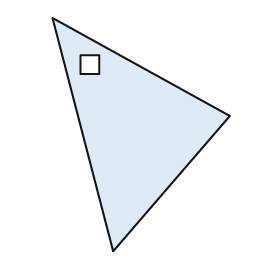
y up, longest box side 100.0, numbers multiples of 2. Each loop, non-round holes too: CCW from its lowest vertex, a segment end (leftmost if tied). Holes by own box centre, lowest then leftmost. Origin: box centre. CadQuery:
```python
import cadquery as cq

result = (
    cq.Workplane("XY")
    .moveTo(-12.0, -50.0)
    .lineTo(38.0, 8.0)
    .lineTo(-38.0, 50.0)
    .close()
    .moveTo(-26.0, 26.0)
    .lineTo(-18.0, 26.0)
    .lineTo(-18.0, 34.0)
    .lineTo(-26.0, 34.0)
    .close()
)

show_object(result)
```